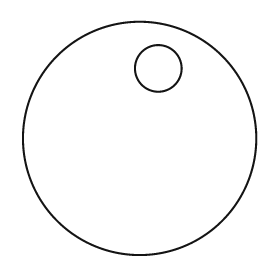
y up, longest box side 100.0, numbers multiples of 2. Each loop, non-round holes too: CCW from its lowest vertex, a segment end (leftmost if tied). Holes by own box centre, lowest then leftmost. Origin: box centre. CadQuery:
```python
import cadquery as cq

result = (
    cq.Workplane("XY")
    .moveTo(0.0, 0.0)
    .circle(50.0)
    .moveTo(8.0, 30.0)
    .circle(10.0)
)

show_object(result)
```